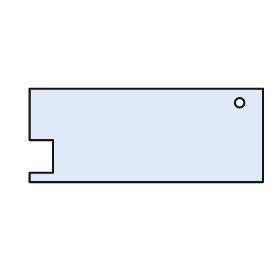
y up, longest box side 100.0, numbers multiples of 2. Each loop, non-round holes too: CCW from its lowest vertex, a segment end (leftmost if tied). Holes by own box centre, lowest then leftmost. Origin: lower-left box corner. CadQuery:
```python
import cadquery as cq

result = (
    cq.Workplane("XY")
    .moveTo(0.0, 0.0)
    .lineTo(100.0, 0.0)
    .lineTo(100.0, 40.0)
    .lineTo(0.0, 40.0)
    .lineTo(0.0, 18.0)
    .lineTo(10.0, 18.0)
    .lineTo(10.0, 4.0)
    .lineTo(0.0, 4.0)
    .close()
    .moveTo(90.0, 34.0)
    .circle(2.0)
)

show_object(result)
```